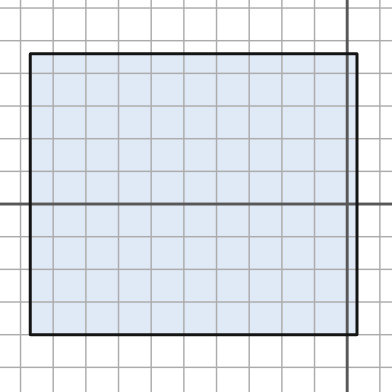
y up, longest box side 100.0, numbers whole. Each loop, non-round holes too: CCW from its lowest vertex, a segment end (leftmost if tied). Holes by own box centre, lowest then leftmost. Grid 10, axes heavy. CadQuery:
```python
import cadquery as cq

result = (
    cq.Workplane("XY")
    .moveTo(-97.0, -40.0)
    .lineTo(3.0, -40.0)
    .lineTo(3.0, 46.0)
    .lineTo(-97.0, 46.0)
    .close()
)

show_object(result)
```